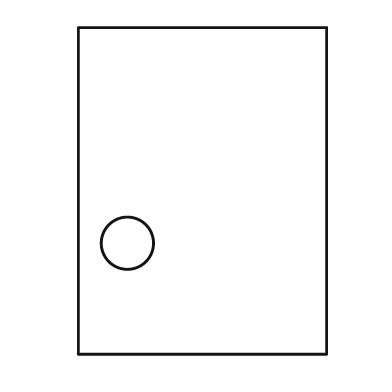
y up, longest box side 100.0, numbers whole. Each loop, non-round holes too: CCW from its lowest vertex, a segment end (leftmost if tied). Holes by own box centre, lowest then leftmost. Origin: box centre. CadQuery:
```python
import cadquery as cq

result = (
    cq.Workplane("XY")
    .moveTo(-38.0, -50.0)
    .lineTo(38.0, -50.0)
    .lineTo(38.0, 50.0)
    .lineTo(-38.0, 50.0)
    .close()
    .moveTo(-23.0, -16.0)
    .circle(8.0)
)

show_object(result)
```